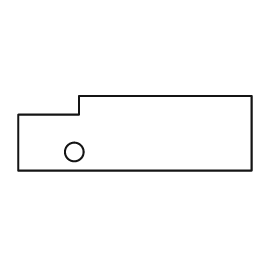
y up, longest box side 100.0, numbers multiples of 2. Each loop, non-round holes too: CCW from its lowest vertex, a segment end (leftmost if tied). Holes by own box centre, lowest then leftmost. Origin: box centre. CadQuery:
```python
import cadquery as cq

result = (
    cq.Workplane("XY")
    .moveTo(-50.0, -16.0)
    .lineTo(50.0, -16.0)
    .lineTo(50.0, 16.0)
    .lineTo(-24.0, 16.0)
    .lineTo(-24.0, 8.0)
    .lineTo(-50.0, 8.0)
    .close()
    .moveTo(-26.0, -8.0)
    .circle(4.0)
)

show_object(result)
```